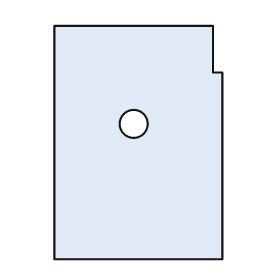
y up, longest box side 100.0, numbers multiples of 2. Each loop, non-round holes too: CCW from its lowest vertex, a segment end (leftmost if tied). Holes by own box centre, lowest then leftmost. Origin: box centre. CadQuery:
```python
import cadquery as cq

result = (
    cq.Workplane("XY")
    .moveTo(-36.0, -50.0)
    .lineTo(36.0, -50.0)
    .lineTo(36.0, 30.0)
    .lineTo(32.0, 30.0)
    .lineTo(32.0, 50.0)
    .lineTo(-36.0, 50.0)
    .close()
    .moveTo(-2.0, 8.0)
    .circle(6.0)
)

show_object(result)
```